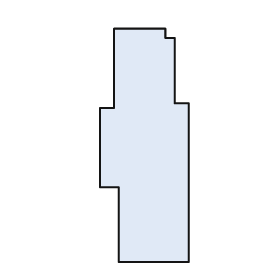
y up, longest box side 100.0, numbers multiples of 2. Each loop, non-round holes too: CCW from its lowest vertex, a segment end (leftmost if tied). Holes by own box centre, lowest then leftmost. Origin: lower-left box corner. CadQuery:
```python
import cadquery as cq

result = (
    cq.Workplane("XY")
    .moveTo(8.0, 0.0)
    .lineTo(38.0, 0.0)
    .lineTo(38.0, 68.0)
    .lineTo(32.0, 68.0)
    .lineTo(32.0, 96.0)
    .lineTo(28.0, 96.0)
    .lineTo(28.0, 100.0)
    .lineTo(6.0, 100.0)
    .lineTo(6.0, 66.0)
    .lineTo(0.0, 66.0)
    .lineTo(0.0, 32.0)
    .lineTo(8.0, 32.0)
    .close()
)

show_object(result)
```